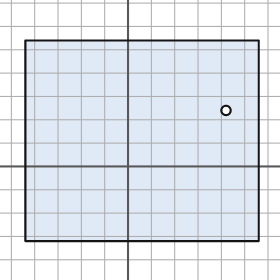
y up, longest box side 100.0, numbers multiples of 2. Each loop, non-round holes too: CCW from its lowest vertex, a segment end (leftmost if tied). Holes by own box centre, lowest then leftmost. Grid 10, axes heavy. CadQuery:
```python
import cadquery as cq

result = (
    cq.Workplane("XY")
    .moveTo(-44.0, -32.0)
    .lineTo(56.0, -32.0)
    .lineTo(56.0, 54.0)
    .lineTo(-44.0, 54.0)
    .close()
    .moveTo(42.0, 24.0)
    .circle(2.0)
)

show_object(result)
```